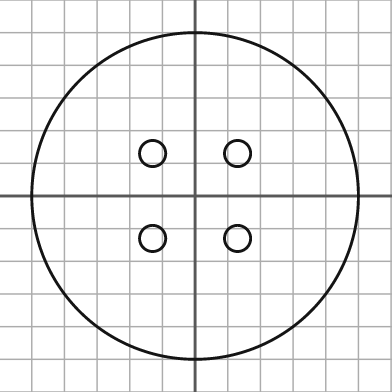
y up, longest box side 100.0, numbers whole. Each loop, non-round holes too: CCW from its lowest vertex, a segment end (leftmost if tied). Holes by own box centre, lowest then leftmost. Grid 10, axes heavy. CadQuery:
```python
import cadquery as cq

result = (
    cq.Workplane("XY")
    .moveTo(0.0, 0.0)
    .circle(50.0)
    .moveTo(-13.0, -13.0)
    .circle(4.0)
    .moveTo(13.0, -13.0)
    .circle(4.0)
    .moveTo(-13.0, 13.0)
    .circle(4.0)
    .moveTo(13.0, 13.0)
    .circle(4.0)
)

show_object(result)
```